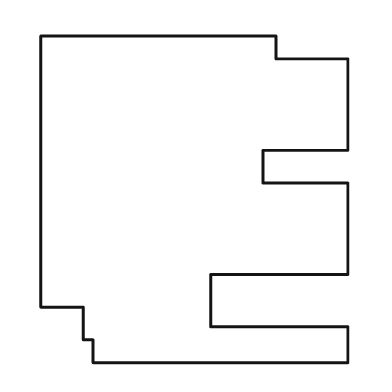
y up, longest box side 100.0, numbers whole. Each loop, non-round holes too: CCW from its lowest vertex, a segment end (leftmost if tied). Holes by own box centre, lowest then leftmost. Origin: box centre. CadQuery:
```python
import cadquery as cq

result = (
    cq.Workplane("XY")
    .moveTo(-31.0, -50.0)
    .lineTo(47.0, -50.0)
    .lineTo(47.0, -39.0)
    .lineTo(5.0, -39.0)
    .lineTo(5.0, -23.0)
    .lineTo(47.0, -23.0)
    .lineTo(47.0, 5.0)
    .lineTo(21.0, 5.0)
    .lineTo(21.0, 15.0)
    .lineTo(47.0, 15.0)
    .lineTo(47.0, 43.0)
    .lineTo(25.0, 43.0)
    .lineTo(25.0, 50.0)
    .lineTo(-47.0, 50.0)
    .lineTo(-47.0, -33.0)
    .lineTo(-34.0, -33.0)
    .lineTo(-34.0, -43.0)
    .lineTo(-31.0, -43.0)
    .close()
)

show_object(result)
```